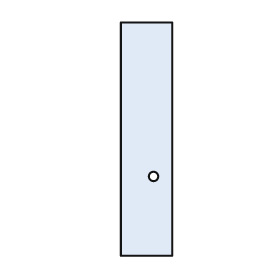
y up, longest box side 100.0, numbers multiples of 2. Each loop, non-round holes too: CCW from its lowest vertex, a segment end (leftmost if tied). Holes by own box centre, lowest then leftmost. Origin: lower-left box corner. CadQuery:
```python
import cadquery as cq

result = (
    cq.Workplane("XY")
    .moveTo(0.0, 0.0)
    .lineTo(22.0, 0.0)
    .lineTo(22.0, 100.0)
    .lineTo(0.0, 100.0)
    .close()
    .moveTo(14.0, 34.0)
    .circle(2.0)
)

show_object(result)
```